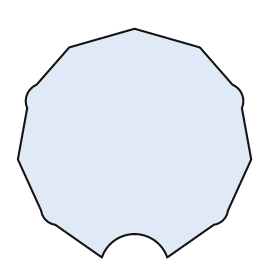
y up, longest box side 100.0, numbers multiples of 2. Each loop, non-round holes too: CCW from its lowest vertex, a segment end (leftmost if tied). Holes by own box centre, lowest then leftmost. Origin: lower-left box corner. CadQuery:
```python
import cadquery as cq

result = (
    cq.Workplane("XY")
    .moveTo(36.0, 0.0)
    .threePointArc((50.0, 10.0), (64.0, 0.0))
    .lineTo(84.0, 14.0)
    .threePointArc((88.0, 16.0), (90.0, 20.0))
    .lineTo(100.0, 42.0)
    .lineTo(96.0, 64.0)
    .threePointArc((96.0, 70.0), (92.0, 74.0))
    .lineTo(78.0, 90.0)
    .lineTo(50.0, 98.0)
    .lineTo(22.0, 90.0)
    .lineTo(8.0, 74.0)
    .threePointArc((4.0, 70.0), (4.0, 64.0))
    .lineTo(0.0, 42.0)
    .lineTo(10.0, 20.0)
    .threePointArc((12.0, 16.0), (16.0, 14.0))
    .close()
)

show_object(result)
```